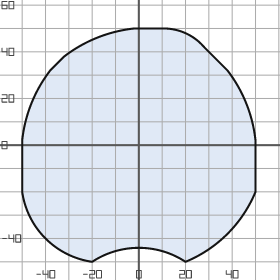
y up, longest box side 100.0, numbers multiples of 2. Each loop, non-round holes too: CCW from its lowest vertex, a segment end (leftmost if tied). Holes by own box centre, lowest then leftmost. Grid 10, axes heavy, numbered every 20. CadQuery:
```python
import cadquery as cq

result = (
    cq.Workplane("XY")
    .moveTo(-20.0, -50.0)
    .threePointArc((0.0, -44.0), (20.0, -50.0))
    .threePointArc((38.0, -38.0), (50.0, -20.0))
    .lineTo(50.0, 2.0)
    .threePointArc((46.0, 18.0), (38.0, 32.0))
    .lineTo(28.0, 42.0)
    .threePointArc((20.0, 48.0), (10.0, 50.0))
    .lineTo(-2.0, 50.0)
    .threePointArc((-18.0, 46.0), (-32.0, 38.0))
    .lineTo(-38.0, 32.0)
    .threePointArc((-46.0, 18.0), (-50.0, 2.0))
    .lineTo(-50.0, -20.0)
    .threePointArc((-40.0, -40.0), (-20.0, -50.0))
    .close()
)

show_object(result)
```